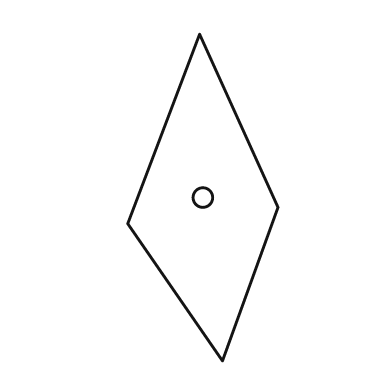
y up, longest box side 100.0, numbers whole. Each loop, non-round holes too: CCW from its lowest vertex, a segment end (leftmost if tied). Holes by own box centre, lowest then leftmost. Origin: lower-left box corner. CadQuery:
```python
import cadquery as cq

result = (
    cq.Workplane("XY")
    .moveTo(29.0, 0.0)
    .lineTo(46.0, 47.0)
    .lineTo(22.0, 100.0)
    .lineTo(0.0, 42.0)
    .close()
    .moveTo(23.0, 50.0)
    .circle(3.0)
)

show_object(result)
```